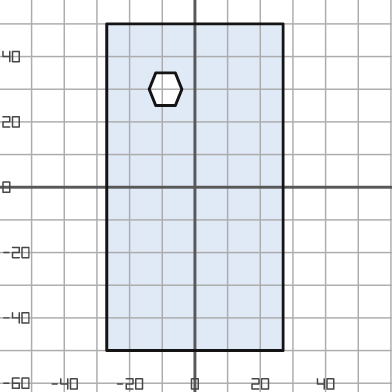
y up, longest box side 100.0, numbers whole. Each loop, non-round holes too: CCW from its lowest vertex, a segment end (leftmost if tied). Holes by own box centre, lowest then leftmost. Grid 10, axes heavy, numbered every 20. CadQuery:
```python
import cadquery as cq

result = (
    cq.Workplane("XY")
    .moveTo(-27.0, -50.0)
    .lineTo(27.0, -50.0)
    .lineTo(27.0, 50.0)
    .lineTo(-27.0, 50.0)
    .close()
    .moveTo(-12.0, 25.0)
    .lineTo(-6.0, 25.0)
    .lineTo(-4.0, 30.0)
    .lineTo(-6.0, 35.0)
    .lineTo(-12.0, 35.0)
    .lineTo(-14.0, 30.0)
    .close()
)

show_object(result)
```